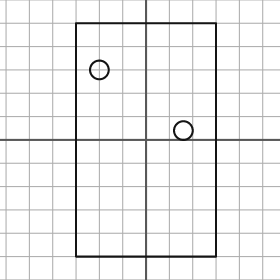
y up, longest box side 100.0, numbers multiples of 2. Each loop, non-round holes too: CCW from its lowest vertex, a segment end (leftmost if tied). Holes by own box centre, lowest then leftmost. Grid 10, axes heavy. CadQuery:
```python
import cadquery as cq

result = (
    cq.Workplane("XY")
    .moveTo(-30.0, -50.0)
    .lineTo(30.0, -50.0)
    .lineTo(30.0, 50.0)
    .lineTo(-30.0, 50.0)
    .close()
    .moveTo(16.0, 4.0)
    .circle(4.0)
    .moveTo(-20.0, 30.0)
    .circle(4.0)
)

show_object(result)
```